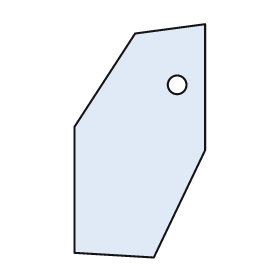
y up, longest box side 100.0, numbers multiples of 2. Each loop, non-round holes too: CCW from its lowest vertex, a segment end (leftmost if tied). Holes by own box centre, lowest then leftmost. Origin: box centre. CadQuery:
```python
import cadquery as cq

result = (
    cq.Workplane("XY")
    .moveTo(6.0, -50.0)
    .lineTo(28.0, -4.0)
    .lineTo(28.0, 50.0)
    .lineTo(-2.0, 46.0)
    .lineTo(-28.0, 6.0)
    .lineTo(-28.0, -48.0)
    .close()
    .moveTo(16.0, 24.0)
    .circle(4.0)
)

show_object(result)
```